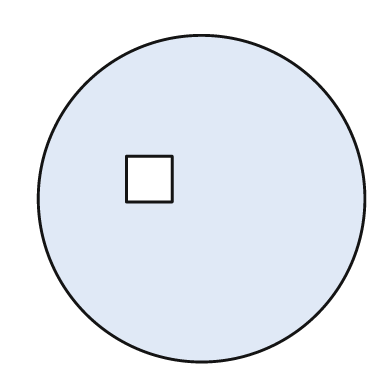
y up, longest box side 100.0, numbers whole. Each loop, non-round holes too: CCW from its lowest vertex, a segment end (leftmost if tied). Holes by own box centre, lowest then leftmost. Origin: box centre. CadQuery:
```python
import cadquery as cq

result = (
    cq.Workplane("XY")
    .moveTo(0.0, 0.0)
    .circle(50.0)
    .moveTo(-23.0, -1.0)
    .lineTo(-9.0, -1.0)
    .lineTo(-9.0, 13.0)
    .lineTo(-23.0, 13.0)
    .close()
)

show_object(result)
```